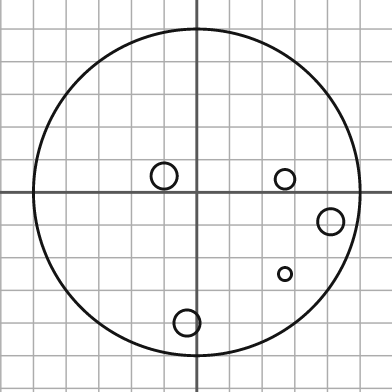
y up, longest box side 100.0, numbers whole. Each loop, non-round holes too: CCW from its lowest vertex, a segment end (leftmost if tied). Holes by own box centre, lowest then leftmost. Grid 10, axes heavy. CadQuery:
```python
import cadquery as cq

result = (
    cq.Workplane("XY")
    .moveTo(0.0, 0.0)
    .circle(50.0)
    .moveTo(-3.0, -40.0)
    .circle(4.0)
    .moveTo(27.0, -25.0)
    .circle(2.0)
    .moveTo(41.0, -9.0)
    .circle(4.0)
    .moveTo(27.0, 4.0)
    .circle(3.0)
    .moveTo(-10.0, 5.0)
    .circle(4.0)
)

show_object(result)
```